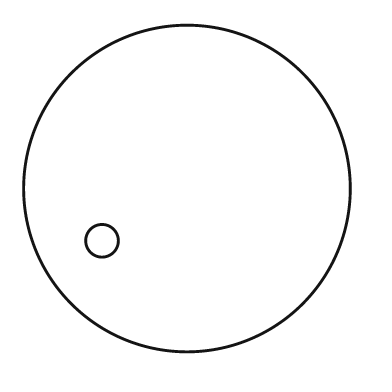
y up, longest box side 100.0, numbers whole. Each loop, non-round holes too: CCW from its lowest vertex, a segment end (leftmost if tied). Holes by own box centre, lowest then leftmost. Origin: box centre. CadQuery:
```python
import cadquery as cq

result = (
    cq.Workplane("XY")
    .moveTo(0.0, 0.0)
    .circle(50.0)
    .moveTo(-26.0, -16.0)
    .circle(5.0)
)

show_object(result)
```